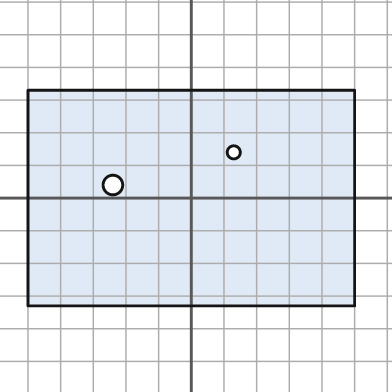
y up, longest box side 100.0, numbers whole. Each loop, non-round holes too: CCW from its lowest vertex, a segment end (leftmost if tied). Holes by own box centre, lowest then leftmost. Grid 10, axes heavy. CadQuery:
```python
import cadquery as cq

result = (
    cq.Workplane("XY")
    .moveTo(-50.0, -33.0)
    .lineTo(50.0, -33.0)
    .lineTo(50.0, 33.0)
    .lineTo(-50.0, 33.0)
    .close()
    .moveTo(-24.0, 4.0)
    .circle(3.0)
    .moveTo(13.0, 14.0)
    .circle(2.0)
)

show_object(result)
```